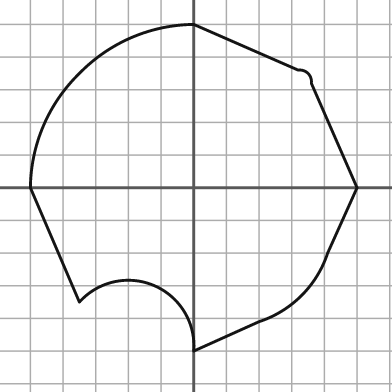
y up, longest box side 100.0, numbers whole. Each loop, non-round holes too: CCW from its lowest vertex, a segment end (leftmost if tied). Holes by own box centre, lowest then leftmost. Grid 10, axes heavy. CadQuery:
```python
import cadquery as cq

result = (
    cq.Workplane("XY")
    .moveTo(0.0, -50.0)
    .lineTo(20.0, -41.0)
    .threePointArc((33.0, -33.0), (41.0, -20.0))
    .lineTo(50.0, 0.0)
    .lineTo(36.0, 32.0)
    .threePointArc((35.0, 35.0), (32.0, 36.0))
    .lineTo(0.0, 50.0)
    .threePointArc((-19.0, 46.0), (-35.0, 35.0))
    .threePointArc((-46.0, 19.0), (-50.0, 0.0))
    .lineTo(-35.0, -35.0)
    .threePointArc((-12.0, -30.0), (0.0, -50.0))
    .close()
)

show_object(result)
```